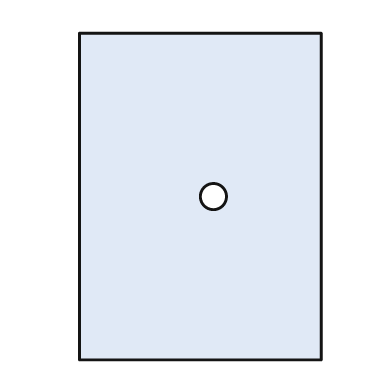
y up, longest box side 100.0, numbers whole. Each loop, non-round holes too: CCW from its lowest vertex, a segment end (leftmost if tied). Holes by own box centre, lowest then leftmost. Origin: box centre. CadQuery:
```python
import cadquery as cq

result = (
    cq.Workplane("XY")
    .moveTo(-37.0, -50.0)
    .lineTo(37.0, -50.0)
    .lineTo(37.0, 50.0)
    .lineTo(-37.0, 50.0)
    .close()
    .moveTo(4.0, 0.0)
    .circle(4.0)
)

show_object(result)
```